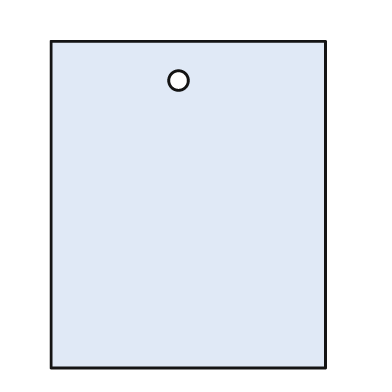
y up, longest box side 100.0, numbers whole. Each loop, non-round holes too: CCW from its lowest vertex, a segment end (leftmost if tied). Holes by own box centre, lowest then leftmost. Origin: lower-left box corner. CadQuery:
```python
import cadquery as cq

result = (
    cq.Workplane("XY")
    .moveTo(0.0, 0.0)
    .lineTo(84.0, 0.0)
    .lineTo(84.0, 100.0)
    .lineTo(0.0, 100.0)
    .close()
    .moveTo(39.0, 88.0)
    .circle(3.0)
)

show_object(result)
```